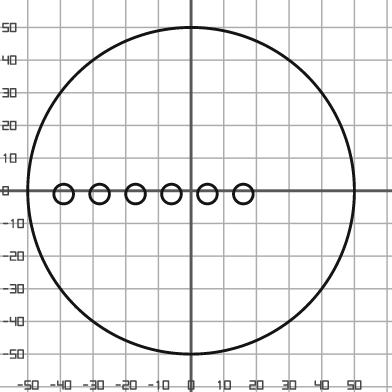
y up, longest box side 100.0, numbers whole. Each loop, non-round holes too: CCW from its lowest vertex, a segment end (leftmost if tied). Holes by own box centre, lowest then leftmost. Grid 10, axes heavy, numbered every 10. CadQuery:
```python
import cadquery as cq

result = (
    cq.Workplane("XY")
    .moveTo(0.0, 0.0)
    .circle(50.0)
    .moveTo(-39.0, -1.0)
    .circle(3.0)
    .moveTo(-28.0, -1.0)
    .circle(3.0)
    .moveTo(-17.0, -1.0)
    .circle(3.0)
    .moveTo(-6.0, -1.0)
    .circle(3.0)
    .moveTo(5.0, -1.0)
    .circle(3.0)
    .moveTo(16.0, -1.0)
    .circle(3.0)
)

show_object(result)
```